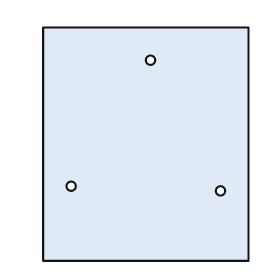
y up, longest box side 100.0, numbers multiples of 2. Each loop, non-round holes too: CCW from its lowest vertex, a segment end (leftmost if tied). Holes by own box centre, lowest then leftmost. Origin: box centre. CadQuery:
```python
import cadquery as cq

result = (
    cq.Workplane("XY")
    .moveTo(-44.0, -50.0)
    .lineTo(44.0, -50.0)
    .lineTo(44.0, 50.0)
    .lineTo(-44.0, 50.0)
    .close()
    .moveTo(32.0, -20.0)
    .circle(2.0)
    .moveTo(-32.0, -18.0)
    .circle(2.0)
    .moveTo(2.0, 36.0)
    .circle(2.0)
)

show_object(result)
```